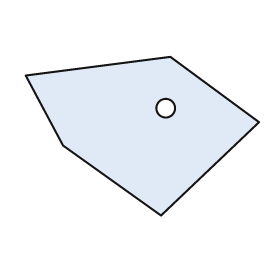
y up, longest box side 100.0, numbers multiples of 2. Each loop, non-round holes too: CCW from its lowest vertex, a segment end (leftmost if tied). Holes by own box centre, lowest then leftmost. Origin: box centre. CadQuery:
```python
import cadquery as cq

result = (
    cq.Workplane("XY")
    .moveTo(8.0, -34.0)
    .lineTo(50.0, 6.0)
    .lineTo(12.0, 34.0)
    .lineTo(-50.0, 26.0)
    .lineTo(-34.0, -4.0)
    .close()
    .moveTo(10.0, 12.0)
    .circle(4.0)
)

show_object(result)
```